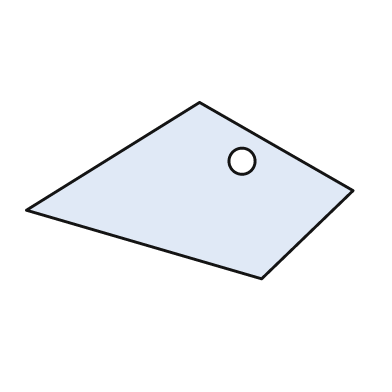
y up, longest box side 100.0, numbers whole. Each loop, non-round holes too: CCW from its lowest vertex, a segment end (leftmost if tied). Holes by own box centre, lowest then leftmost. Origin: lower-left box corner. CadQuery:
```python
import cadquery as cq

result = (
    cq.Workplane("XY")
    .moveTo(72.0, 0.0)
    .lineTo(100.0, 27.0)
    .lineTo(53.0, 54.0)
    .lineTo(0.0, 21.0)
    .close()
    .moveTo(66.0, 36.0)
    .circle(4.0)
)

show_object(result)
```